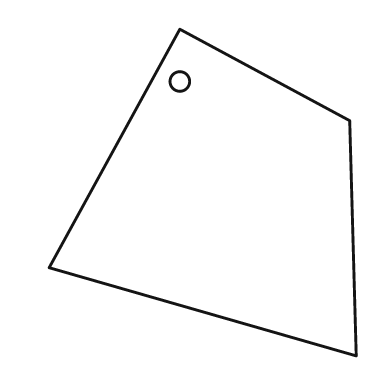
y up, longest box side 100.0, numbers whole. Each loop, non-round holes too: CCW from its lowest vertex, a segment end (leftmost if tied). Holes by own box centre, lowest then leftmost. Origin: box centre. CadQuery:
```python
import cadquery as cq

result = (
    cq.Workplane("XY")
    .moveTo(47.0, -50.0)
    .lineTo(45.0, 22.0)
    .lineTo(-7.0, 50.0)
    .lineTo(-47.0, -23.0)
    .close()
    .moveTo(-7.0, 34.0)
    .circle(3.0)
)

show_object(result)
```